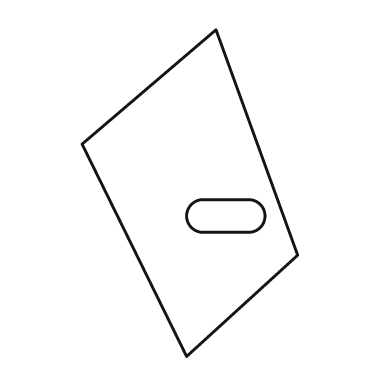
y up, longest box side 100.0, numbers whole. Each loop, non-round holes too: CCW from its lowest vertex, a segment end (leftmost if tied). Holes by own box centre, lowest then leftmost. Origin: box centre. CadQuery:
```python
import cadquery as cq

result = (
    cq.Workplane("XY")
    .moveTo(-1.0, -50.0)
    .lineTo(33.0, -19.0)
    .lineTo(8.0, 50.0)
    .lineTo(-33.0, 15.0)
    .close()
    .moveTo(4.0, -12.0)
    .lineTo(18.0, -12.0)
    .threePointArc((23.0, -7.0), (18.0, -2.0))
    .lineTo(4.0, -2.0)
    .threePointArc((-1.0, -7.0), (4.0, -12.0))
    .close()
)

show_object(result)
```